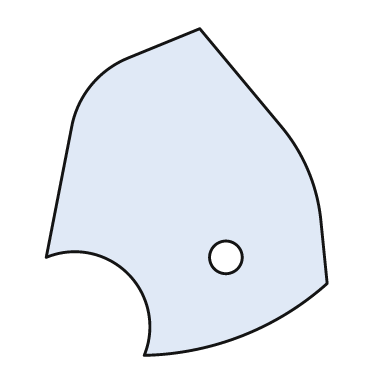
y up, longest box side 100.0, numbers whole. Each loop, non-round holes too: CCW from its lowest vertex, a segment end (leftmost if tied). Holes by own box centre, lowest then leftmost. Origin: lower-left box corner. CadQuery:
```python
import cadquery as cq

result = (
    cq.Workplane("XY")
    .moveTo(30.0, 0.0)
    .threePointArc((60.0, 6.0), (86.0, 22.0))
    .lineTo(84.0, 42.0)
    .threePointArc((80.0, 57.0), (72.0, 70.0))
    .lineTo(47.0, 100.0)
    .lineTo(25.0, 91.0)
    .threePointArc((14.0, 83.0), (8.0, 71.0))
    .lineTo(0.0, 30.0)
    .threePointArc((25.0, 25.0), (30.0, 0.0))
    .close()
    .moveTo(55.0, 30.0)
    .circle(5.0)
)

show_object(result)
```